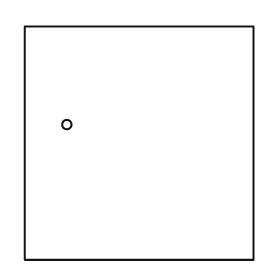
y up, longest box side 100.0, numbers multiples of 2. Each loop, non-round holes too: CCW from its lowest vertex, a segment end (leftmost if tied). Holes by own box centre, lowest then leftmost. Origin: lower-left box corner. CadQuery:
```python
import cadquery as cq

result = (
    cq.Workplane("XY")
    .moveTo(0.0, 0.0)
    .lineTo(98.0, 0.0)
    .lineTo(98.0, 100.0)
    .lineTo(0.0, 100.0)
    .close()
    .moveTo(18.0, 58.0)
    .circle(2.0)
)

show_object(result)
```